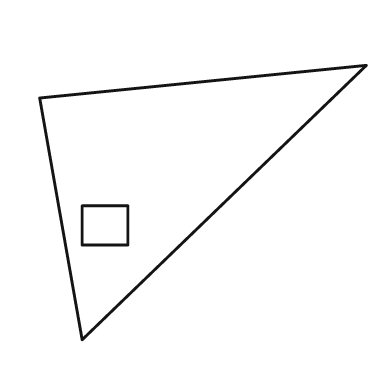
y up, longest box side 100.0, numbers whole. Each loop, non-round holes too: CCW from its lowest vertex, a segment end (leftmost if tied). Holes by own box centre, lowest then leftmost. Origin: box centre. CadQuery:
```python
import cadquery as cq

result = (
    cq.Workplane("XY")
    .moveTo(-37.0, -42.0)
    .lineTo(50.0, 42.0)
    .lineTo(-50.0, 32.0)
    .close()
    .moveTo(-37.0, -13.0)
    .lineTo(-23.0, -13.0)
    .lineTo(-23.0, -1.0)
    .lineTo(-37.0, -1.0)
    .close()
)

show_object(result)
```